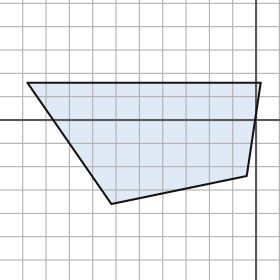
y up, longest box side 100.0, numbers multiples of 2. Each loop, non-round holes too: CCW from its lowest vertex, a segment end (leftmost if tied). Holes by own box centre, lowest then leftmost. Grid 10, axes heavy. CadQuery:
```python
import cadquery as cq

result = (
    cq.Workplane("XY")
    .moveTo(-62.0, -36.0)
    .lineTo(-4.0, -24.0)
    .lineTo(2.0, 16.0)
    .lineTo(-98.0, 16.0)
    .close()
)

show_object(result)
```